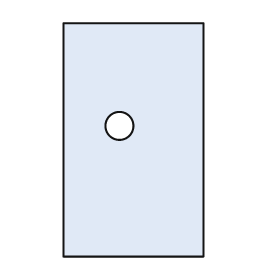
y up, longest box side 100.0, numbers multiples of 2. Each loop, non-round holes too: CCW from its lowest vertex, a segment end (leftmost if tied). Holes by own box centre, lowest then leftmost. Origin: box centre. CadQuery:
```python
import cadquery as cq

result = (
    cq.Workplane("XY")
    .moveTo(-30.0, -50.0)
    .lineTo(30.0, -50.0)
    .lineTo(30.0, 50.0)
    .lineTo(-30.0, 50.0)
    .close()
    .moveTo(-6.0, 6.0)
    .circle(6.0)
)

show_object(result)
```